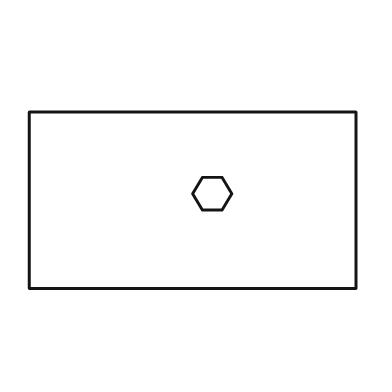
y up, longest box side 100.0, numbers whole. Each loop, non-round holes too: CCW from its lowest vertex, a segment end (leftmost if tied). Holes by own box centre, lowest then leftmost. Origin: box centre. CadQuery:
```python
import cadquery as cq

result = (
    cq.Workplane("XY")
    .moveTo(-50.0, -27.0)
    .lineTo(50.0, -27.0)
    .lineTo(50.0, 27.0)
    .lineTo(-50.0, 27.0)
    .close()
    .moveTo(3.0, -3.0)
    .lineTo(9.0, -3.0)
    .lineTo(12.0, 2.0)
    .lineTo(9.0, 7.0)
    .lineTo(3.0, 7.0)
    .lineTo(0.0, 2.0)
    .close()
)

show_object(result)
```